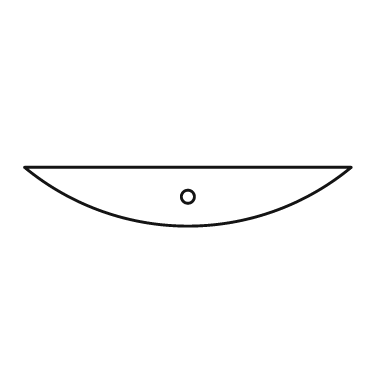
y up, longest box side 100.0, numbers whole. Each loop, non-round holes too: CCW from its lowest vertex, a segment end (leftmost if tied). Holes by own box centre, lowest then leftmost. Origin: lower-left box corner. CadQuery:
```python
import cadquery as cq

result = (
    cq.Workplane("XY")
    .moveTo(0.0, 18.0)
    .threePointArc((50.0, 0.0), (100.0, 18.0))
    .close()
    .moveTo(50.0, 9.0)
    .circle(2.0)
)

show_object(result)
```